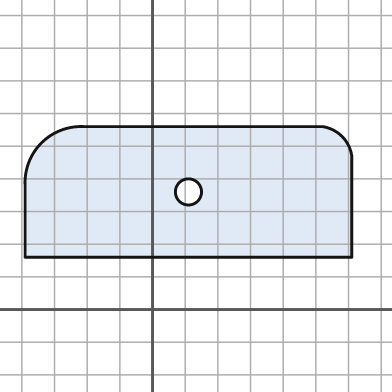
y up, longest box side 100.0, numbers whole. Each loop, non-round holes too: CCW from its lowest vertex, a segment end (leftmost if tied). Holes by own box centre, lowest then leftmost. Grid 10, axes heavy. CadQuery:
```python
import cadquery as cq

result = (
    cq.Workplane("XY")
    .moveTo(-39.0, 16.0)
    .lineTo(61.0, 16.0)
    .lineTo(61.0, 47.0)
    .threePointArc((58.0, 53.0), (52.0, 56.0))
    .lineTo(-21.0, 56.0)
    .threePointArc((-34.0, 51.0), (-39.0, 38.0))
    .close()
    .moveTo(11.0, 36.0)
    .circle(4.0)
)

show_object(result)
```